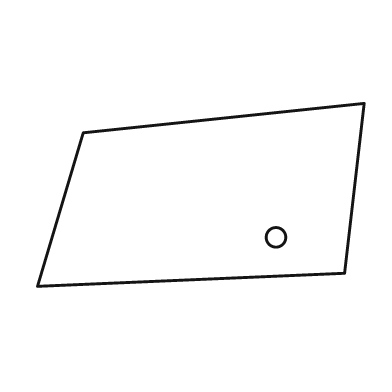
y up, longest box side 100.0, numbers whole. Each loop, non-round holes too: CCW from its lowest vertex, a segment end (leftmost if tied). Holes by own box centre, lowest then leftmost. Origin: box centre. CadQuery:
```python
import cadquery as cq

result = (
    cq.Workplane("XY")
    .moveTo(-50.0, -28.0)
    .lineTo(44.0, -24.0)
    .lineTo(50.0, 28.0)
    .lineTo(-36.0, 19.0)
    .close()
    .moveTo(23.0, -13.0)
    .circle(3.0)
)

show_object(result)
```